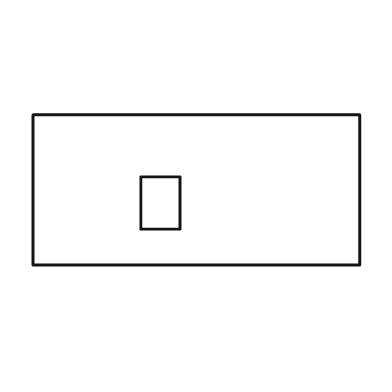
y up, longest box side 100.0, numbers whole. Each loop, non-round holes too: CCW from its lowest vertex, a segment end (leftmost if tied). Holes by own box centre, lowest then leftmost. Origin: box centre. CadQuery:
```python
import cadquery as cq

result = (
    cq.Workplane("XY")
    .moveTo(-50.0, -23.0)
    .lineTo(50.0, -23.0)
    .lineTo(50.0, 23.0)
    .lineTo(-50.0, 23.0)
    .close()
    .moveTo(-17.0, -12.0)
    .lineTo(-5.0, -12.0)
    .lineTo(-5.0, 4.0)
    .lineTo(-17.0, 4.0)
    .close()
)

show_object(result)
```